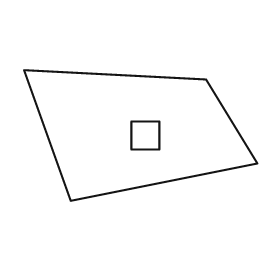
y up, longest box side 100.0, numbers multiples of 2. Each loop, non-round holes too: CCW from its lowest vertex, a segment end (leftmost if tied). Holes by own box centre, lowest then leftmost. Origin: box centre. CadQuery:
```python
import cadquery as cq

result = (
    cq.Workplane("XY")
    .moveTo(-30.0, -28.0)
    .lineTo(50.0, -12.0)
    .lineTo(28.0, 24.0)
    .lineTo(-50.0, 28.0)
    .close()
    .moveTo(-4.0, -6.0)
    .lineTo(8.0, -6.0)
    .lineTo(8.0, 6.0)
    .lineTo(-4.0, 6.0)
    .close()
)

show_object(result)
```